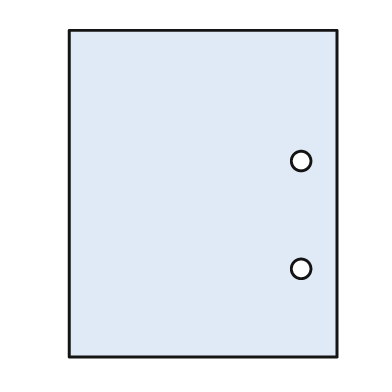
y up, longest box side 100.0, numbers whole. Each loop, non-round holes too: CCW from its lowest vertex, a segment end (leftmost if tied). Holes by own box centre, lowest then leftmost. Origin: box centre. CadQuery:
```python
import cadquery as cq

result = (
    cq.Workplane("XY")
    .moveTo(-41.0, -50.0)
    .lineTo(41.0, -50.0)
    .lineTo(41.0, 50.0)
    .lineTo(-41.0, 50.0)
    .close()
    .moveTo(30.0, -23.0)
    .circle(3.0)
    .moveTo(30.0, 10.0)
    .circle(3.0)
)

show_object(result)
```